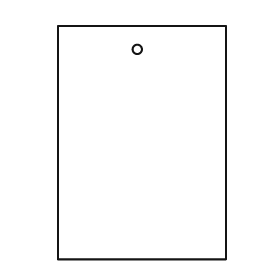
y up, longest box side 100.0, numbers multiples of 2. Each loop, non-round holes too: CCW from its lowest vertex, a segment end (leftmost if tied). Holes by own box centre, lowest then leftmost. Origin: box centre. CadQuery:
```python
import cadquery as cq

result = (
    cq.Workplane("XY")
    .moveTo(-36.0, -50.0)
    .lineTo(36.0, -50.0)
    .lineTo(36.0, 50.0)
    .lineTo(-36.0, 50.0)
    .close()
    .moveTo(-2.0, 40.0)
    .circle(2.0)
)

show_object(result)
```